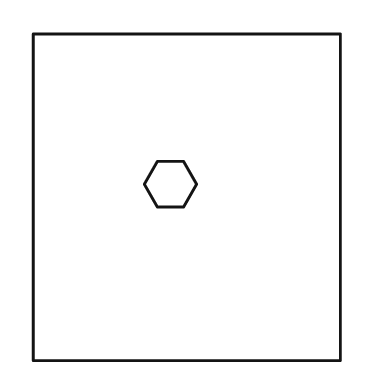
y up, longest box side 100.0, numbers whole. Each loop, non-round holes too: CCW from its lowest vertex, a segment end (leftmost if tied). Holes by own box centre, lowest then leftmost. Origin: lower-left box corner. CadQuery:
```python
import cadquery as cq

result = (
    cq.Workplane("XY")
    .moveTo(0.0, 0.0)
    .lineTo(94.0, 0.0)
    .lineTo(94.0, 100.0)
    .lineTo(0.0, 100.0)
    .close()
    .moveTo(38.0, 47.0)
    .lineTo(46.0, 47.0)
    .lineTo(50.0, 54.0)
    .lineTo(46.0, 61.0)
    .lineTo(38.0, 61.0)
    .lineTo(34.0, 54.0)
    .close()
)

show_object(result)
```